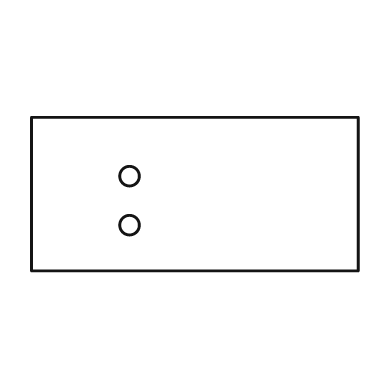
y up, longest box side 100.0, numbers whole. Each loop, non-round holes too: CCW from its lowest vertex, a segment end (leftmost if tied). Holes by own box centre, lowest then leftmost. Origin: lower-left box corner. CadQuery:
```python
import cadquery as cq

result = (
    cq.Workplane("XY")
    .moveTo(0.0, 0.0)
    .lineTo(100.0, 0.0)
    .lineTo(100.0, 47.0)
    .lineTo(0.0, 47.0)
    .close()
    .moveTo(30.0, 14.0)
    .circle(3.0)
    .moveTo(30.0, 29.0)
    .circle(3.0)
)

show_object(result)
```